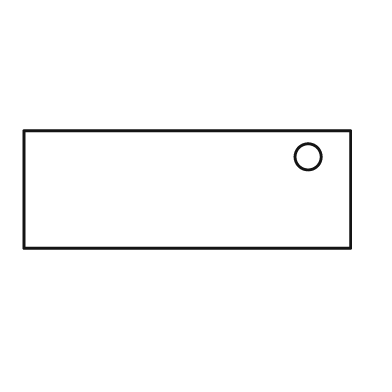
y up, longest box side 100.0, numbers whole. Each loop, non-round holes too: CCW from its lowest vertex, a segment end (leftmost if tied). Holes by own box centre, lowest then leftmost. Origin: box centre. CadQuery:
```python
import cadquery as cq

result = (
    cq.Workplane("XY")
    .moveTo(-50.0, -18.0)
    .lineTo(50.0, -18.0)
    .lineTo(50.0, 18.0)
    .lineTo(-50.0, 18.0)
    .close()
    .moveTo(37.0, 10.0)
    .circle(4.0)
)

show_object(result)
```